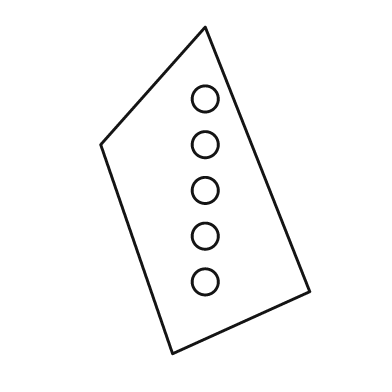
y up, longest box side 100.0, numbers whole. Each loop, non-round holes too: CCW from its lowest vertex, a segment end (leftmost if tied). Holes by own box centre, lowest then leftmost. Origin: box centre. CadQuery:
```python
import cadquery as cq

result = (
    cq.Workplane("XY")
    .moveTo(-10.0, -50.0)
    .lineTo(32.0, -31.0)
    .lineTo(0.0, 50.0)
    .lineTo(-32.0, 14.0)
    .close()
    .moveTo(0.0, -28.0)
    .circle(4.0)
    .moveTo(0.0, -14.0)
    .circle(4.0)
    .moveTo(0.0, 0.0)
    .circle(4.0)
    .moveTo(0.0, 14.0)
    .circle(4.0)
    .moveTo(0.0, 28.0)
    .circle(4.0)
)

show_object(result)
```